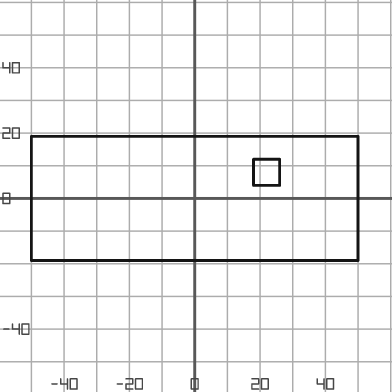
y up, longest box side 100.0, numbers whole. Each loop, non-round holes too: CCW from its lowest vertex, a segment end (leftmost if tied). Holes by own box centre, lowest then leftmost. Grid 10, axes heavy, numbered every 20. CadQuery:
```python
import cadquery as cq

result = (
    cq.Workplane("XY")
    .moveTo(-50.0, -19.0)
    .lineTo(50.0, -19.0)
    .lineTo(50.0, 19.0)
    .lineTo(-50.0, 19.0)
    .close()
    .moveTo(18.0, 4.0)
    .lineTo(26.0, 4.0)
    .lineTo(26.0, 12.0)
    .lineTo(18.0, 12.0)
    .close()
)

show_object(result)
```